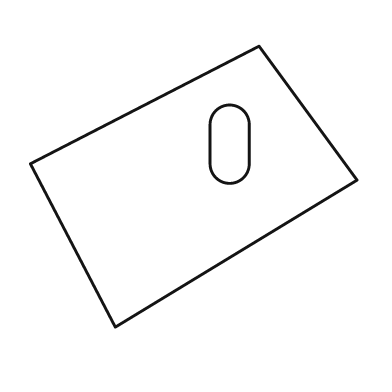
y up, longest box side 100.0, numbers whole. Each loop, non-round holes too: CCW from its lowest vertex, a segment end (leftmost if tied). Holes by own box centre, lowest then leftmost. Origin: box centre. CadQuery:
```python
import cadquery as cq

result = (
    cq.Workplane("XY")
    .moveTo(-24.0, -43.0)
    .lineTo(50.0, 2.0)
    .lineTo(20.0, 43.0)
    .lineTo(-50.0, 7.0)
    .close()
    .moveTo(5.0, 7.0)
    .threePointArc((11.0, 1.0), (17.0, 7.0))
    .lineTo(17.0, 19.0)
    .threePointArc((11.0, 25.0), (5.0, 19.0))
    .close()
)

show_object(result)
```